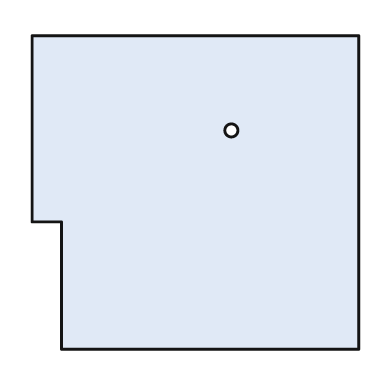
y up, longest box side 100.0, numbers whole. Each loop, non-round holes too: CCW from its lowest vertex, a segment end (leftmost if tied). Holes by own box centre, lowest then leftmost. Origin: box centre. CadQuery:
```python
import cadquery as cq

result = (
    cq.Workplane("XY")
    .moveTo(-41.0, -48.0)
    .lineTo(50.0, -48.0)
    .lineTo(50.0, 48.0)
    .lineTo(-50.0, 48.0)
    .lineTo(-50.0, -9.0)
    .lineTo(-41.0, -9.0)
    .close()
    .moveTo(11.0, 19.0)
    .circle(2.0)
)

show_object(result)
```